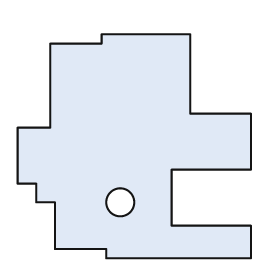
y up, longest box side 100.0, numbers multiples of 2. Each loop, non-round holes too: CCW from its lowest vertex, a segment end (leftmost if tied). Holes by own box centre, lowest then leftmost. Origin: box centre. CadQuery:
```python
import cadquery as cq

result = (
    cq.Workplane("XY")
    .moveTo(-12.0, -48.0)
    .lineTo(50.0, -48.0)
    .lineTo(50.0, -34.0)
    .lineTo(16.0, -34.0)
    .lineTo(16.0, -10.0)
    .lineTo(50.0, -10.0)
    .lineTo(50.0, 14.0)
    .lineTo(24.0, 14.0)
    .lineTo(24.0, 48.0)
    .lineTo(-14.0, 48.0)
    .lineTo(-14.0, 44.0)
    .lineTo(-36.0, 44.0)
    .lineTo(-36.0, 8.0)
    .lineTo(-50.0, 8.0)
    .lineTo(-50.0, -16.0)
    .lineTo(-42.0, -16.0)
    .lineTo(-42.0, -24.0)
    .lineTo(-34.0, -24.0)
    .lineTo(-34.0, -44.0)
    .lineTo(-12.0, -44.0)
    .close()
    .moveTo(-6.0, -24.0)
    .circle(6.0)
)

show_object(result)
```